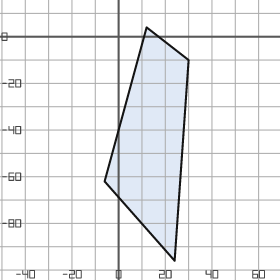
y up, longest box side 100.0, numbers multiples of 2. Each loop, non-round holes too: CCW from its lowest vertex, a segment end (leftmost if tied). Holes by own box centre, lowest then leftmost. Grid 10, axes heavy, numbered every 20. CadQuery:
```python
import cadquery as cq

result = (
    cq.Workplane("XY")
    .moveTo(24.0, -96.0)
    .lineTo(30.0, -10.0)
    .lineTo(12.0, 4.0)
    .lineTo(-6.0, -62.0)
    .close()
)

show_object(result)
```